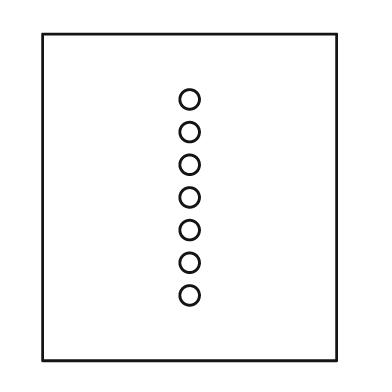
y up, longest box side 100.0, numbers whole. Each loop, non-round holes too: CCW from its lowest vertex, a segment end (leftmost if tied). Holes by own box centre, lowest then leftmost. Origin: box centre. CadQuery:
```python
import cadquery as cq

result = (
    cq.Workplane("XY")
    .moveTo(-45.0, -50.0)
    .lineTo(45.0, -50.0)
    .lineTo(45.0, 50.0)
    .lineTo(-45.0, 50.0)
    .close()
    .moveTo(0.0, -30.0)
    .circle(3.0)
    .moveTo(0.0, -20.0)
    .circle(3.0)
    .moveTo(0.0, -10.0)
    .circle(3.0)
    .moveTo(0.0, 0.0)
    .circle(3.0)
    .moveTo(0.0, 10.0)
    .circle(3.0)
    .moveTo(0.0, 20.0)
    .circle(3.0)
    .moveTo(0.0, 30.0)
    .circle(3.0)
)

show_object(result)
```